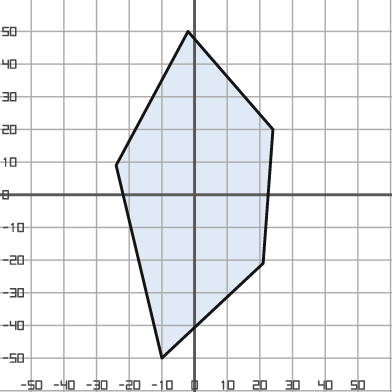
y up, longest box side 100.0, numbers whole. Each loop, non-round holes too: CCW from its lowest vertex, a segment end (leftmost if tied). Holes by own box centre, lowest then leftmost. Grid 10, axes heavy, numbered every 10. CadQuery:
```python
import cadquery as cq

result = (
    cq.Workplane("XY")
    .moveTo(-10.0, -50.0)
    .lineTo(21.0, -21.0)
    .lineTo(24.0, 20.0)
    .lineTo(-2.0, 50.0)
    .lineTo(-24.0, 9.0)
    .close()
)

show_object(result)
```